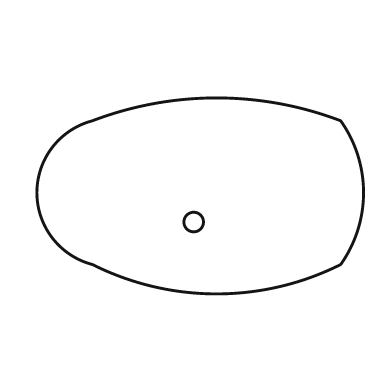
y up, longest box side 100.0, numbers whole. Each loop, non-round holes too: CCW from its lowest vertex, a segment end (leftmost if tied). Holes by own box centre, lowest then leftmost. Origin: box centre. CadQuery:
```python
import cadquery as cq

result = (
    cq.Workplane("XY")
    .moveTo(-33.0, -21.0)
    .threePointArc((5.0, -30.0), (43.0, -21.0))
    .threePointArc((50.0, 1.0), (43.0, 23.0))
    .threePointArc((5.0, 30.0), (-33.0, 23.0))
    .threePointArc((-50.0, 1.0), (-33.0, -21.0))
    .close()
    .moveTo(-2.0, -8.0)
    .circle(3.0)
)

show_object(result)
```